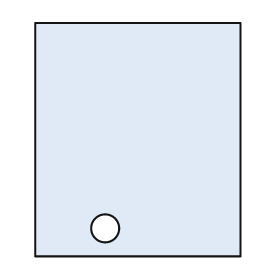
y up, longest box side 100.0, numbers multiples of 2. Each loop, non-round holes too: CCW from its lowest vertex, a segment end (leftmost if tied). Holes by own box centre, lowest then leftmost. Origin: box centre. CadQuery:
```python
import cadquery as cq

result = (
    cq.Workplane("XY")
    .moveTo(-44.0, -50.0)
    .lineTo(44.0, -50.0)
    .lineTo(44.0, 50.0)
    .lineTo(-44.0, 50.0)
    .close()
    .moveTo(-14.0, -38.0)
    .circle(6.0)
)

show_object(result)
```